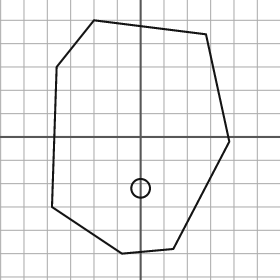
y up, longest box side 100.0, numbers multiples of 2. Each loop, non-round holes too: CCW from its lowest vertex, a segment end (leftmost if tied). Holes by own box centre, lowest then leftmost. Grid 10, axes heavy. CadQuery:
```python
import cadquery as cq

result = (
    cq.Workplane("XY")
    .moveTo(-8.0, -50.0)
    .lineTo(14.0, -48.0)
    .lineTo(38.0, -2.0)
    .lineTo(28.0, 44.0)
    .lineTo(-20.0, 50.0)
    .lineTo(-36.0, 30.0)
    .lineTo(-38.0, -30.0)
    .close()
    .moveTo(0.0, -22.0)
    .circle(4.0)
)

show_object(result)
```